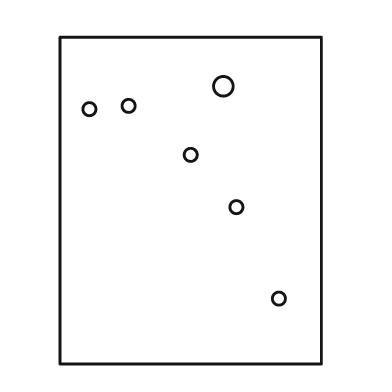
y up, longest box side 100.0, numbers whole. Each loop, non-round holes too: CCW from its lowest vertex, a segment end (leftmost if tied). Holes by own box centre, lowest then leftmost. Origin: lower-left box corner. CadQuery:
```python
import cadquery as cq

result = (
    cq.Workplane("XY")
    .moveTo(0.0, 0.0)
    .lineTo(80.0, 0.0)
    .lineTo(80.0, 100.0)
    .lineTo(0.0, 100.0)
    .close()
    .moveTo(67.0, 20.0)
    .circle(2.0)
    .moveTo(54.0, 48.0)
    .circle(2.0)
    .moveTo(40.0, 64.0)
    .circle(2.0)
    .moveTo(9.0, 78.0)
    .circle(2.0)
    .moveTo(21.0, 79.0)
    .circle(2.0)
    .moveTo(50.0, 85.0)
    .circle(3.0)
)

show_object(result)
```